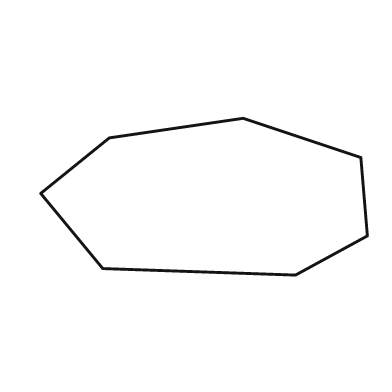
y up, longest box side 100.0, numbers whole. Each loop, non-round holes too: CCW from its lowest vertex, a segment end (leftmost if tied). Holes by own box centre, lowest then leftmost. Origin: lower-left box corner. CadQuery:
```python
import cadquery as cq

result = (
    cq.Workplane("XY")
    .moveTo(78.0, 0.0)
    .lineTo(100.0, 12.0)
    .lineTo(98.0, 36.0)
    .lineTo(62.0, 48.0)
    .lineTo(21.0, 42.0)
    .lineTo(0.0, 25.0)
    .lineTo(19.0, 2.0)
    .close()
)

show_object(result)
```